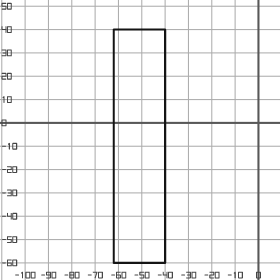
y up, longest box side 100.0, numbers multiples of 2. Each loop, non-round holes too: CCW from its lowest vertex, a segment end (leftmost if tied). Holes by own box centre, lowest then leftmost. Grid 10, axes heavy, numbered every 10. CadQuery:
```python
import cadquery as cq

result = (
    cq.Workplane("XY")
    .moveTo(-62.0, -60.0)
    .lineTo(-40.0, -60.0)
    .lineTo(-40.0, 40.0)
    .lineTo(-62.0, 40.0)
    .close()
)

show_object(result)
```